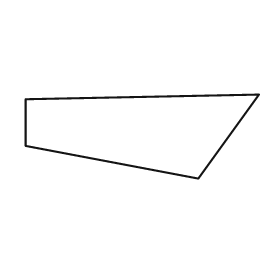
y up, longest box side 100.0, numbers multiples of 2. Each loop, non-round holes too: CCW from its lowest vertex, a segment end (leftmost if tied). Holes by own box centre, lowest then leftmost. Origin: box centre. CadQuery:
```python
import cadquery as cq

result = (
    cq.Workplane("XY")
    .moveTo(24.0, -18.0)
    .lineTo(50.0, 18.0)
    .lineTo(-50.0, 16.0)
    .lineTo(-50.0, -4.0)
    .close()
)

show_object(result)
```